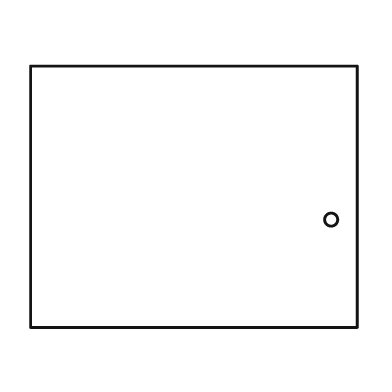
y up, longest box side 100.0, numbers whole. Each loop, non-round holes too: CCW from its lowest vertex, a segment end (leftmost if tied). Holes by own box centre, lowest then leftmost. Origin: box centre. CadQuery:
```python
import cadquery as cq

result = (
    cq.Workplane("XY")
    .moveTo(-50.0, -40.0)
    .lineTo(50.0, -40.0)
    .lineTo(50.0, 40.0)
    .lineTo(-50.0, 40.0)
    .close()
    .moveTo(42.0, -7.0)
    .circle(2.0)
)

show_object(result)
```